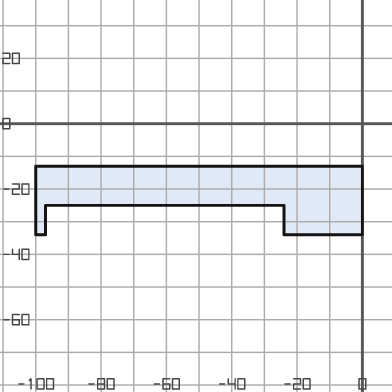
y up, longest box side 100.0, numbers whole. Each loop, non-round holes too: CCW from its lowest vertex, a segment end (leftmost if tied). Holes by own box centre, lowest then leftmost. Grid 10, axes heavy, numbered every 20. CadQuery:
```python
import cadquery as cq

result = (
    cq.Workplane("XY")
    .moveTo(-100.0, -34.0)
    .lineTo(-97.0, -34.0)
    .lineTo(-97.0, -25.0)
    .lineTo(-24.0, -25.0)
    .lineTo(-24.0, -34.0)
    .lineTo(0.0, -34.0)
    .lineTo(0.0, -13.0)
    .lineTo(-100.0, -13.0)
    .close()
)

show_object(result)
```